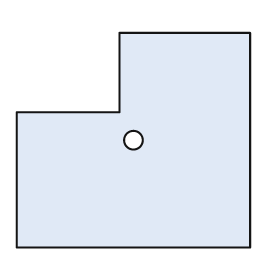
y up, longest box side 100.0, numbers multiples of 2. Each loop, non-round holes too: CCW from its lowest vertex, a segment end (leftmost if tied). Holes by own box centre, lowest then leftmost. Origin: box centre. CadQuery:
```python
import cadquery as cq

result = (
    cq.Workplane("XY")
    .moveTo(-50.0, -46.0)
    .lineTo(50.0, -46.0)
    .lineTo(50.0, 46.0)
    .lineTo(-6.0, 46.0)
    .lineTo(-6.0, 12.0)
    .lineTo(-50.0, 12.0)
    .close()
    .moveTo(0.0, 0.0)
    .circle(4.0)
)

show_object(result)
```